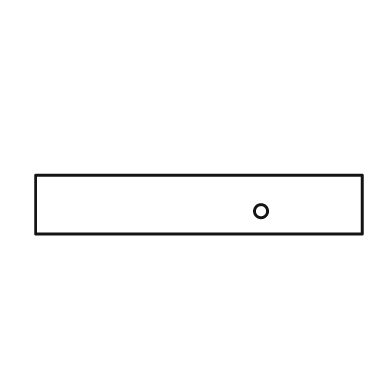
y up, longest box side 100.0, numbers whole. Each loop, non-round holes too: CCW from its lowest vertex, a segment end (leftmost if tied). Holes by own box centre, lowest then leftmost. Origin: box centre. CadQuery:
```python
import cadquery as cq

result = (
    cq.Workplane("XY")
    .moveTo(-50.0, -9.0)
    .lineTo(50.0, -9.0)
    .lineTo(50.0, 9.0)
    .lineTo(-50.0, 9.0)
    .close()
    .moveTo(19.0, -2.0)
    .circle(2.0)
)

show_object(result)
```